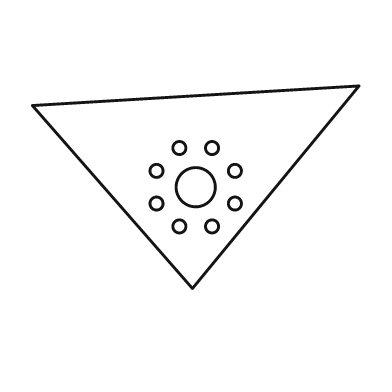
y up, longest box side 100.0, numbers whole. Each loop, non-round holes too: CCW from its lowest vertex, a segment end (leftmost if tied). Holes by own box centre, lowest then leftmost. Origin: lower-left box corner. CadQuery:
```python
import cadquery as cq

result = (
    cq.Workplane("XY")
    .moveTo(49.0, 0.0)
    .lineTo(100.0, 62.0)
    .lineTo(0.0, 56.0)
    .close()
    .moveTo(45.0, 19.0)
    .circle(2.0)
    .moveTo(55.0, 19.0)
    .circle(2.0)
    .moveTo(38.0, 26.0)
    .circle(2.0)
    .moveTo(62.0, 26.0)
    .circle(2.0)
    .moveTo(50.0, 31.0)
    .circle(6.0)
    .moveTo(38.0, 36.0)
    .circle(2.0)
    .moveTo(62.0, 36.0)
    .circle(2.0)
    .moveTo(45.0, 43.0)
    .circle(2.0)
    .moveTo(55.0, 43.0)
    .circle(2.0)
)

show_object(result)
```